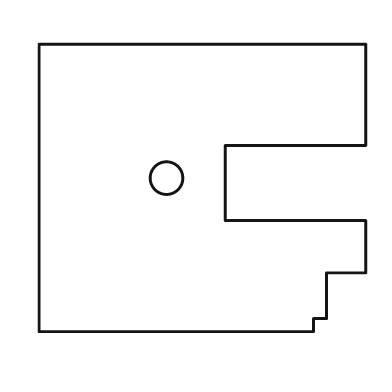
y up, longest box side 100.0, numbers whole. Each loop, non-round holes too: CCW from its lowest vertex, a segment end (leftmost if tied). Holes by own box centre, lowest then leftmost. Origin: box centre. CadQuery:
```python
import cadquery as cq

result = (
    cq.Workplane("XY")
    .moveTo(-50.0, -44.0)
    .lineTo(34.0, -44.0)
    .lineTo(34.0, -40.0)
    .lineTo(38.0, -40.0)
    .lineTo(38.0, -26.0)
    .lineTo(50.0, -26.0)
    .lineTo(50.0, -10.0)
    .lineTo(7.0, -10.0)
    .lineTo(7.0, 13.0)
    .lineTo(50.0, 13.0)
    .lineTo(50.0, 44.0)
    .lineTo(-50.0, 44.0)
    .close()
    .moveTo(-11.0, 3.0)
    .circle(5.0)
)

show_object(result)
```